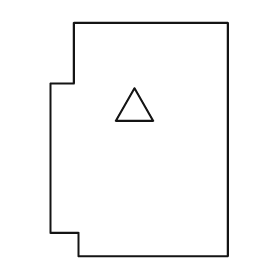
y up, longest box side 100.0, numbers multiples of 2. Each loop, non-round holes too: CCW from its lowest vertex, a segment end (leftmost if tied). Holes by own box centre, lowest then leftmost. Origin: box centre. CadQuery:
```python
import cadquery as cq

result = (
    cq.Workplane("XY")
    .moveTo(-26.0, -50.0)
    .lineTo(38.0, -50.0)
    .lineTo(38.0, 50.0)
    .lineTo(-28.0, 50.0)
    .lineTo(-28.0, 24.0)
    .lineTo(-38.0, 24.0)
    .lineTo(-38.0, -40.0)
    .lineTo(-26.0, -40.0)
    .close()
    .moveTo(-10.0, 8.0)
    .lineTo(6.0, 8.0)
    .lineTo(-2.0, 22.0)
    .close()
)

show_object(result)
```